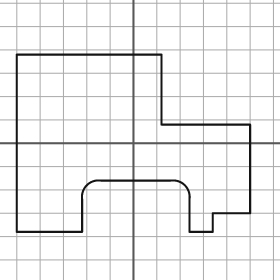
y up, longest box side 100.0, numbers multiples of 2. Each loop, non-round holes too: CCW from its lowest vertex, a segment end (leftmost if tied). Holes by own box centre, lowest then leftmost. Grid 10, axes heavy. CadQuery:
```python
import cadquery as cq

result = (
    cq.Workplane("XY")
    .moveTo(-50.0, -38.0)
    .lineTo(-22.0, -38.0)
    .lineTo(-22.0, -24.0)
    .threePointArc((-20.0, -18.0), (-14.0, -16.0))
    .lineTo(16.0, -16.0)
    .threePointArc((22.0, -18.0), (24.0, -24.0))
    .lineTo(24.0, -38.0)
    .lineTo(34.0, -38.0)
    .lineTo(34.0, -30.0)
    .lineTo(50.0, -30.0)
    .lineTo(50.0, 8.0)
    .lineTo(12.0, 8.0)
    .lineTo(12.0, 38.0)
    .lineTo(-50.0, 38.0)
    .close()
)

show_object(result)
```